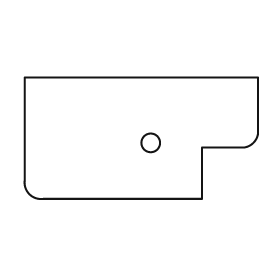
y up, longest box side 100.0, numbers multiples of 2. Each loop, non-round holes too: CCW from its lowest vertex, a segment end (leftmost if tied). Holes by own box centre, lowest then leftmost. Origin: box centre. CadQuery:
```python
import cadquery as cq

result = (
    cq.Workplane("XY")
    .moveTo(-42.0, -26.0)
    .lineTo(26.0, -26.0)
    .lineTo(26.0, -4.0)
    .lineTo(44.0, -4.0)
    .threePointArc((48.0, -2.0), (50.0, 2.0))
    .lineTo(50.0, 26.0)
    .lineTo(-50.0, 26.0)
    .lineTo(-50.0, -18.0)
    .threePointArc((-48.0, -24.0), (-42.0, -26.0))
    .close()
    .moveTo(4.0, -2.0)
    .circle(4.0)
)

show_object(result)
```